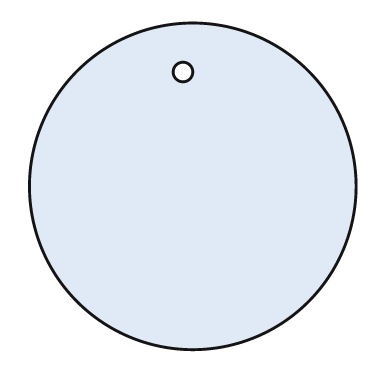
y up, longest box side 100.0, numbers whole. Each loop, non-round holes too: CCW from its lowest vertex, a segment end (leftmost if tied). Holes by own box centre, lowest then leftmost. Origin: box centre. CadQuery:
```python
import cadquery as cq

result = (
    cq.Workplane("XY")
    .moveTo(0.0, 0.0)
    .circle(50.0)
    .moveTo(-3.0, 35.0)
    .circle(3.0)
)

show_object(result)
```